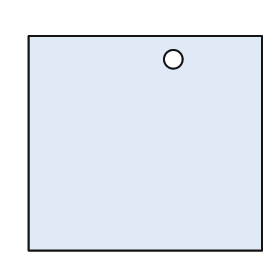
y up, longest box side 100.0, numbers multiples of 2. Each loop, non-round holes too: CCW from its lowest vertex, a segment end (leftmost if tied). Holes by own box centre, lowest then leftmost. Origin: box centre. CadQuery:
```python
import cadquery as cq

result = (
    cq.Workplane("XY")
    .moveTo(-50.0, -46.0)
    .lineTo(50.0, -46.0)
    .lineTo(50.0, 46.0)
    .lineTo(-50.0, 46.0)
    .close()
    .moveTo(12.0, 36.0)
    .circle(4.0)
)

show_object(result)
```